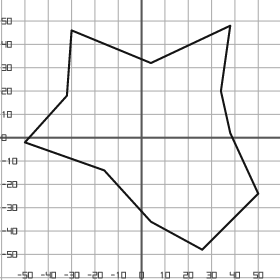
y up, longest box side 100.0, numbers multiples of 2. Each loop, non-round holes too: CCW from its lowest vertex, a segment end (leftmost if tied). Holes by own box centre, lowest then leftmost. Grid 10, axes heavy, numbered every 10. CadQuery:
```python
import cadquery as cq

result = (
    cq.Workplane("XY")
    .moveTo(26.0, -48.0)
    .lineTo(50.0, -24.0)
    .lineTo(38.0, 2.0)
    .lineTo(34.0, 20.0)
    .lineTo(38.0, 48.0)
    .lineTo(4.0, 32.0)
    .lineTo(-30.0, 46.0)
    .lineTo(-32.0, 18.0)
    .lineTo(-50.0, -2.0)
    .lineTo(-16.0, -14.0)
    .lineTo(4.0, -36.0)
    .close()
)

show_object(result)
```